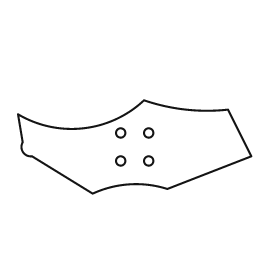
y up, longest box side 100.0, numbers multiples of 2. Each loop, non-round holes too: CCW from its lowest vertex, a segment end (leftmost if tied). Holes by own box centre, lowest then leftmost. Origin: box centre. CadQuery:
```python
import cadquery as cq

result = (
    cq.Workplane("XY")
    .moveTo(-18.0, -20.0)
    .threePointArc((-2.0, -16.0), (14.0, -18.0))
    .lineTo(50.0, -4.0)
    .lineTo(40.0, 16.0)
    .threePointArc((22.0, 16.0), (4.0, 20.0))
    .threePointArc((-22.0, 8.0), (-50.0, 14.0))
    .lineTo(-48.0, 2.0)
    .threePointArc((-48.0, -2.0), (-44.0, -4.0))
    .close()
    .moveTo(-6.0, -6.0)
    .circle(2.0)
    .moveTo(6.0, -6.0)
    .circle(2.0)
    .moveTo(-6.0, 6.0)
    .circle(2.0)
    .moveTo(6.0, 6.0)
    .circle(2.0)
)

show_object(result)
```